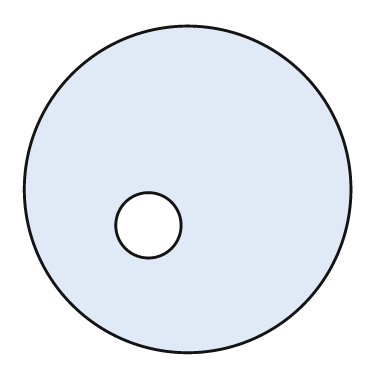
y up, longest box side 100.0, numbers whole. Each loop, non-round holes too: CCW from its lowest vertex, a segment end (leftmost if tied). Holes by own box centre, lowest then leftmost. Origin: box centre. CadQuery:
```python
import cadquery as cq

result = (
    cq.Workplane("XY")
    .moveTo(0.0, 0.0)
    .circle(50.0)
    .moveTo(-12.0, -11.0)
    .circle(10.0)
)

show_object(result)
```